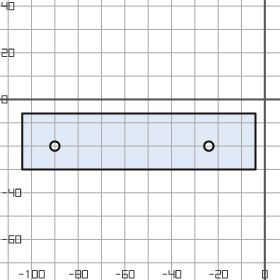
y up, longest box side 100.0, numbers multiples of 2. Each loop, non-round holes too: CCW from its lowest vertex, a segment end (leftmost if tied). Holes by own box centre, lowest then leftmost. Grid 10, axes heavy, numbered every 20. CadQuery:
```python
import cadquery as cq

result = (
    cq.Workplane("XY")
    .moveTo(-104.0, -30.0)
    .lineTo(-4.0, -30.0)
    .lineTo(-4.0, -6.0)
    .lineTo(-104.0, -6.0)
    .close()
    .moveTo(-90.0, -20.0)
    .circle(2.0)
    .moveTo(-24.0, -20.0)
    .circle(2.0)
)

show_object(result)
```